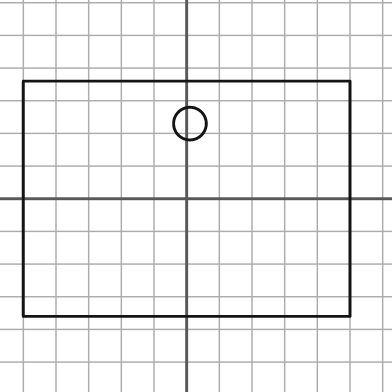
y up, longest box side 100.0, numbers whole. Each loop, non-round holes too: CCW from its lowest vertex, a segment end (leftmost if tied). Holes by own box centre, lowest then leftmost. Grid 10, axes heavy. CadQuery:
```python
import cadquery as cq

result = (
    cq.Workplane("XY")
    .moveTo(-50.0, -36.0)
    .lineTo(50.0, -36.0)
    .lineTo(50.0, 36.0)
    .lineTo(-50.0, 36.0)
    .close()
    .moveTo(1.0, 23.0)
    .circle(5.0)
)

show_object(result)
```